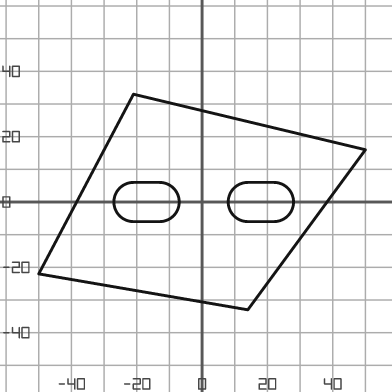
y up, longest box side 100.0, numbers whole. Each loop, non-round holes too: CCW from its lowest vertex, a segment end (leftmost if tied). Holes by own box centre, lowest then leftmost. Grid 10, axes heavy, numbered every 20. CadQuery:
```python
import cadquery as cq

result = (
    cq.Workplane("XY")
    .moveTo(14.0, -33.0)
    .lineTo(50.0, 16.0)
    .lineTo(-21.0, 33.0)
    .lineTo(-50.0, -22.0)
    .close()
    .moveTo(-21.0, -6.0)
    .lineTo(-13.0, -6.0)
    .threePointArc((-7.0, 0.0), (-13.0, 6.0))
    .lineTo(-21.0, 6.0)
    .threePointArc((-27.0, 0.0), (-21.0, -6.0))
    .close()
    .moveTo(14.0, -6.0)
    .lineTo(22.0, -6.0)
    .threePointArc((28.0, 0.0), (22.0, 6.0))
    .lineTo(14.0, 6.0)
    .threePointArc((8.0, 0.0), (14.0, -6.0))
    .close()
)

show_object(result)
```